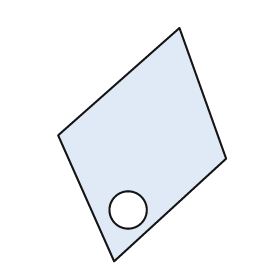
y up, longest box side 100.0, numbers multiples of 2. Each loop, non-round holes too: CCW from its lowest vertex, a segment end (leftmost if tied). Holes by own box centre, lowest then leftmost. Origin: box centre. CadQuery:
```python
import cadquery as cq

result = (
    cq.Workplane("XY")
    .moveTo(-12.0, -50.0)
    .lineTo(36.0, -6.0)
    .lineTo(16.0, 50.0)
    .lineTo(-36.0, 4.0)
    .close()
    .moveTo(-6.0, -28.0)
    .circle(8.0)
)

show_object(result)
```